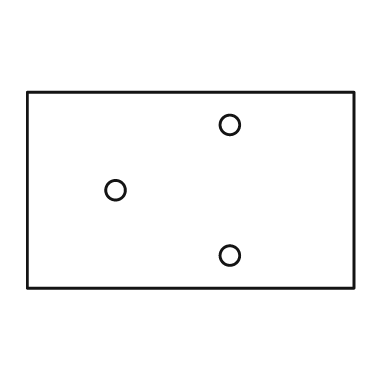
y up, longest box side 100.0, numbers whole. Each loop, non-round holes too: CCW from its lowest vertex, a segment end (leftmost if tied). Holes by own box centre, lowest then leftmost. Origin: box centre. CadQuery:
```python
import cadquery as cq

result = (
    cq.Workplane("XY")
    .moveTo(-50.0, -30.0)
    .lineTo(50.0, -30.0)
    .lineTo(50.0, 30.0)
    .lineTo(-50.0, 30.0)
    .close()
    .moveTo(12.0, -20.0)
    .circle(3.0)
    .moveTo(-23.0, 0.0)
    .circle(3.0)
    .moveTo(12.0, 20.0)
    .circle(3.0)
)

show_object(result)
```